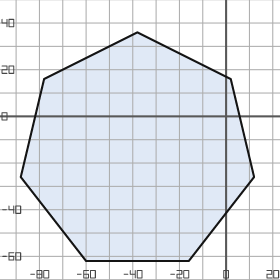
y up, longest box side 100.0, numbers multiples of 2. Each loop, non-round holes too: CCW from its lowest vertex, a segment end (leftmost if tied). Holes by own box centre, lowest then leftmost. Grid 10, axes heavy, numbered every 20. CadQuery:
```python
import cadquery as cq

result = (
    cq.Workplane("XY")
    .moveTo(-60.0, -62.0)
    .lineTo(-16.0, -62.0)
    .lineTo(12.0, -26.0)
    .lineTo(2.0, 16.0)
    .lineTo(-38.0, 36.0)
    .lineTo(-78.0, 16.0)
    .lineTo(-88.0, -26.0)
    .close()
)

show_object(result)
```